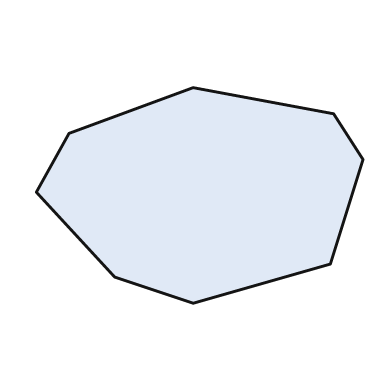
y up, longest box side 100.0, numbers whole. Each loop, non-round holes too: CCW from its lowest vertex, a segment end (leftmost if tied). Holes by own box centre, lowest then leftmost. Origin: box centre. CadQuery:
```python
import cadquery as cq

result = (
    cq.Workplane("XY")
    .moveTo(-2.0, -33.0)
    .lineTo(40.0, -21.0)
    .lineTo(50.0, 11.0)
    .lineTo(41.0, 25.0)
    .lineTo(-2.0, 33.0)
    .lineTo(-40.0, 19.0)
    .lineTo(-50.0, 1.0)
    .lineTo(-26.0, -25.0)
    .close()
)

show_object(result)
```